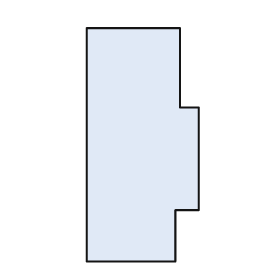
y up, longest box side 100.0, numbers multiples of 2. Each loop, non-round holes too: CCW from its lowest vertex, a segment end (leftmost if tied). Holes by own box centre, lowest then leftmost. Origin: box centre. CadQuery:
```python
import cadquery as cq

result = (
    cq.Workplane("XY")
    .moveTo(-24.0, -50.0)
    .lineTo(14.0, -50.0)
    .lineTo(14.0, -28.0)
    .lineTo(24.0, -28.0)
    .lineTo(24.0, 16.0)
    .lineTo(16.0, 16.0)
    .lineTo(16.0, 50.0)
    .lineTo(-24.0, 50.0)
    .close()
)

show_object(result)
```